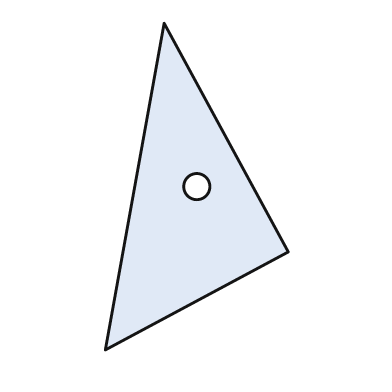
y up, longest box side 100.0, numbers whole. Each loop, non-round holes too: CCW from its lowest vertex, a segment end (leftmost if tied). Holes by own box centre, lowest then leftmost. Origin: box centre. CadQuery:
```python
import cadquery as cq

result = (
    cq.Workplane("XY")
    .moveTo(-28.0, -50.0)
    .lineTo(28.0, -20.0)
    .lineTo(-10.0, 50.0)
    .close()
    .moveTo(0.0, 0.0)
    .circle(4.0)
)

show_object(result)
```